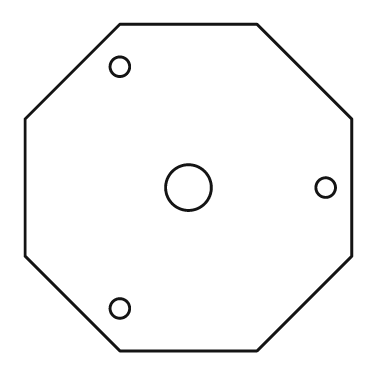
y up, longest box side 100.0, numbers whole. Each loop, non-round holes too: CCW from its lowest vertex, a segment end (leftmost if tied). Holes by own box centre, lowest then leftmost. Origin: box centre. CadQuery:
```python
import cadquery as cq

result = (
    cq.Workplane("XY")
    .moveTo(-21.0, -50.0)
    .lineTo(21.0, -50.0)
    .lineTo(50.0, -21.0)
    .lineTo(50.0, 21.0)
    .lineTo(21.0, 50.0)
    .lineTo(-21.0, 50.0)
    .lineTo(-50.0, 21.0)
    .lineTo(-50.0, -21.0)
    .close()
    .moveTo(-21.0, -37.0)
    .circle(3.0)
    .moveTo(0.0, 0.0)
    .circle(7.0)
    .moveTo(42.0, 0.0)
    .circle(3.0)
    .moveTo(-21.0, 37.0)
    .circle(3.0)
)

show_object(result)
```